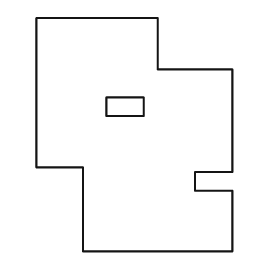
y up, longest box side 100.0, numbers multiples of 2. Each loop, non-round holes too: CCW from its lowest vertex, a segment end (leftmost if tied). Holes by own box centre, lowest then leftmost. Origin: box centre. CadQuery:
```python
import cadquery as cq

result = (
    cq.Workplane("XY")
    .moveTo(-22.0, -50.0)
    .lineTo(42.0, -50.0)
    .lineTo(42.0, -24.0)
    .lineTo(26.0, -24.0)
    .lineTo(26.0, -16.0)
    .lineTo(42.0, -16.0)
    .lineTo(42.0, 28.0)
    .lineTo(10.0, 28.0)
    .lineTo(10.0, 50.0)
    .lineTo(-42.0, 50.0)
    .lineTo(-42.0, -14.0)
    .lineTo(-22.0, -14.0)
    .close()
    .moveTo(-12.0, 8.0)
    .lineTo(4.0, 8.0)
    .lineTo(4.0, 16.0)
    .lineTo(-12.0, 16.0)
    .close()
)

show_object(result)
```